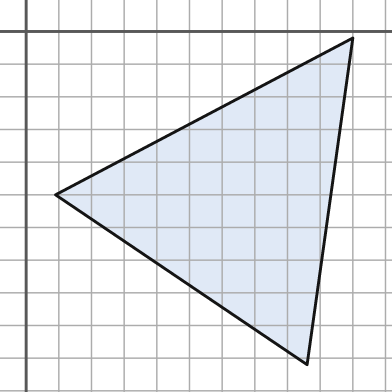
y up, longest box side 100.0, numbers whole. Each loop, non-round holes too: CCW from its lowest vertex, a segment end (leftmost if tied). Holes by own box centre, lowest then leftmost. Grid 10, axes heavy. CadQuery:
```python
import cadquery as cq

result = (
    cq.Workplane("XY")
    .moveTo(86.0, -102.0)
    .lineTo(100.0, -2.0)
    .lineTo(9.0, -50.0)
    .close()
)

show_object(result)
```